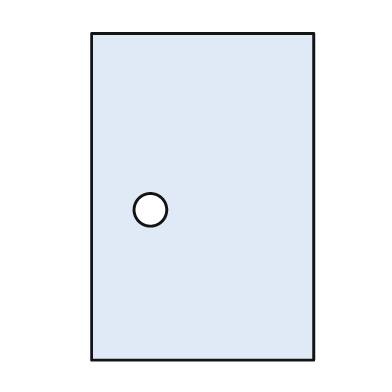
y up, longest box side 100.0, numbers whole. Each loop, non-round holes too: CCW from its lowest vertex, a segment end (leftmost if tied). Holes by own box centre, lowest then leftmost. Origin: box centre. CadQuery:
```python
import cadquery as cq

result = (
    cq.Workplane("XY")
    .moveTo(-34.0, -50.0)
    .lineTo(34.0, -50.0)
    .lineTo(34.0, 50.0)
    .lineTo(-34.0, 50.0)
    .close()
    .moveTo(-16.0, -4.0)
    .circle(5.0)
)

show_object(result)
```